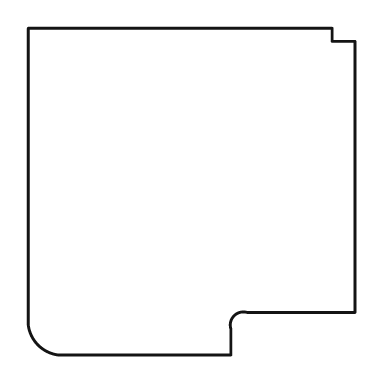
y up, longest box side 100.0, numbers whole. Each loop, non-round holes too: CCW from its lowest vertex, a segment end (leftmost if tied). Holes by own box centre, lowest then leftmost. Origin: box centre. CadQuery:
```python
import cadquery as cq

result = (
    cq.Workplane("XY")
    .moveTo(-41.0, -50.0)
    .lineTo(12.0, -50.0)
    .lineTo(12.0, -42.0)
    .threePointArc((13.0, -38.0), (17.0, -37.0))
    .lineTo(50.0, -37.0)
    .lineTo(50.0, 46.0)
    .lineTo(43.0, 46.0)
    .lineTo(43.0, 50.0)
    .lineTo(-50.0, 50.0)
    .lineTo(-50.0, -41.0)
    .threePointArc((-47.0, -47.0), (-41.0, -50.0))
    .close()
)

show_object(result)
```